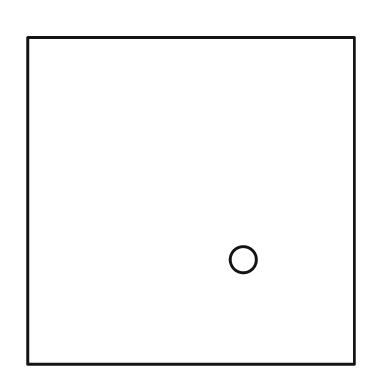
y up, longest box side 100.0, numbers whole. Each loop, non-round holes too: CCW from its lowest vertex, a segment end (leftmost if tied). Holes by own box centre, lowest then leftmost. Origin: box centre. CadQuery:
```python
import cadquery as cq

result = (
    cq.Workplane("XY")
    .moveTo(-50.0, -50.0)
    .lineTo(50.0, -50.0)
    .lineTo(50.0, 50.0)
    .lineTo(-50.0, 50.0)
    .close()
    .moveTo(16.0, -18.0)
    .circle(4.0)
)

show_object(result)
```